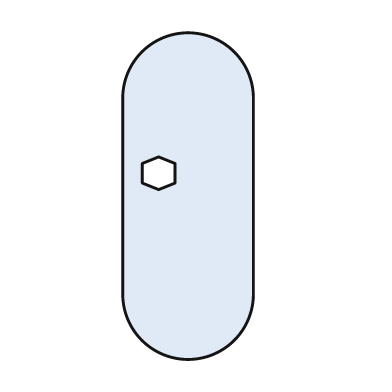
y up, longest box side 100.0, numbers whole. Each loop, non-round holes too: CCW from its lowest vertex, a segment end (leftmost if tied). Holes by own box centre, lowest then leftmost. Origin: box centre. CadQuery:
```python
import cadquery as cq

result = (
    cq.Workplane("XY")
    .moveTo(-20.0, -30.0)
    .threePointArc((0.0, -50.0), (20.0, -30.0))
    .lineTo(20.0, 30.0)
    .threePointArc((0.0, 50.0), (-20.0, 30.0))
    .close()
    .moveTo(-9.0, 2.0)
    .lineTo(-4.0, 4.0)
    .lineTo(-4.0, 10.0)
    .lineTo(-9.0, 12.0)
    .lineTo(-14.0, 10.0)
    .lineTo(-14.0, 4.0)
    .close()
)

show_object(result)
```